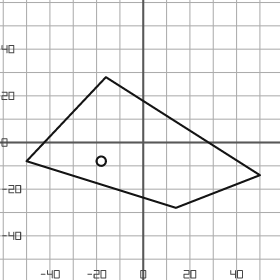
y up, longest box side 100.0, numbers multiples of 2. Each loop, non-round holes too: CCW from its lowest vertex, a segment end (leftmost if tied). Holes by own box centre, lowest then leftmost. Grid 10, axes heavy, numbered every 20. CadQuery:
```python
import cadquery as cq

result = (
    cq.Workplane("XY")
    .moveTo(14.0, -28.0)
    .lineTo(50.0, -14.0)
    .lineTo(-16.0, 28.0)
    .lineTo(-50.0, -8.0)
    .close()
    .moveTo(-18.0, -8.0)
    .circle(2.0)
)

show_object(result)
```